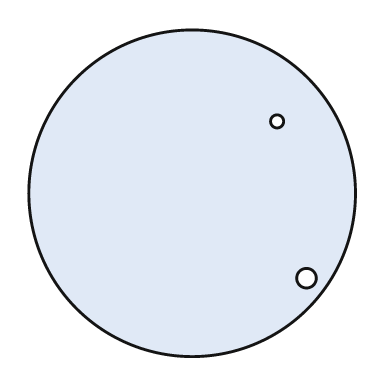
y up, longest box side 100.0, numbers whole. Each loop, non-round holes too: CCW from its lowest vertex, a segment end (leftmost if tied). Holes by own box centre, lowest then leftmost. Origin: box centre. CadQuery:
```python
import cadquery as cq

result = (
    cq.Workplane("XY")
    .moveTo(0.0, 0.0)
    .circle(50.0)
    .moveTo(35.0, -26.0)
    .circle(3.0)
    .moveTo(26.0, 22.0)
    .circle(2.0)
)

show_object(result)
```